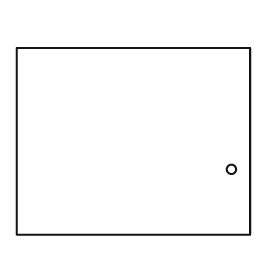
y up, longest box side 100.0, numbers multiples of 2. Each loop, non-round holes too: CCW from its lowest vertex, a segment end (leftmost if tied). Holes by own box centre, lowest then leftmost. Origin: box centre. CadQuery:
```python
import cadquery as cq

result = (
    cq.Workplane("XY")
    .moveTo(-50.0, -40.0)
    .lineTo(50.0, -40.0)
    .lineTo(50.0, 40.0)
    .lineTo(-50.0, 40.0)
    .close()
    .moveTo(42.0, -12.0)
    .circle(2.0)
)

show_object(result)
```